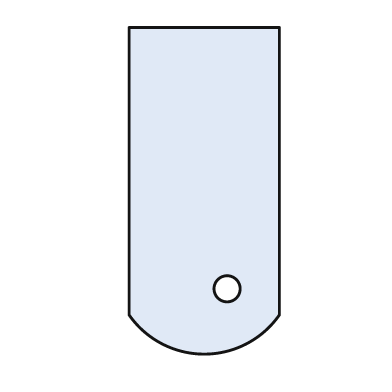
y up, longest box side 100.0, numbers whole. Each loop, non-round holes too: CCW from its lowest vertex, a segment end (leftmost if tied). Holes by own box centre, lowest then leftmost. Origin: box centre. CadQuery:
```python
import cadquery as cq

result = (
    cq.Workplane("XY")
    .moveTo(-23.0, -38.0)
    .threePointArc((0.0, -50.0), (23.0, -38.0))
    .lineTo(23.0, 50.0)
    .lineTo(-23.0, 50.0)
    .close()
    .moveTo(7.0, -30.0)
    .circle(4.0)
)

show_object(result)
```